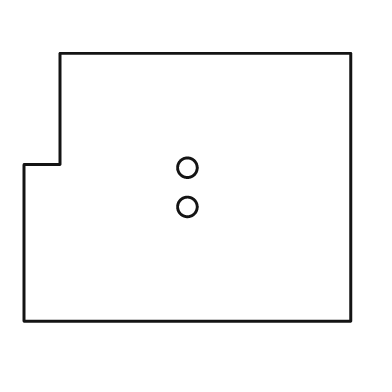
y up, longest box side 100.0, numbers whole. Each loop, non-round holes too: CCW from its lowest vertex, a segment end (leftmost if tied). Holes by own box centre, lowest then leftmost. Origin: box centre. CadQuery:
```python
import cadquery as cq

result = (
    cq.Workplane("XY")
    .moveTo(-50.0, -41.0)
    .lineTo(50.0, -41.0)
    .lineTo(50.0, 41.0)
    .lineTo(-39.0, 41.0)
    .lineTo(-39.0, 7.0)
    .lineTo(-50.0, 7.0)
    .close()
    .moveTo(0.0, -6.0)
    .circle(3.0)
    .moveTo(0.0, 6.0)
    .circle(3.0)
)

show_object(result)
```